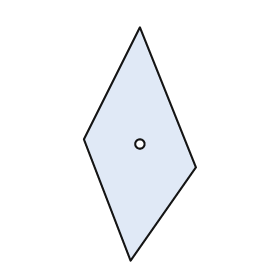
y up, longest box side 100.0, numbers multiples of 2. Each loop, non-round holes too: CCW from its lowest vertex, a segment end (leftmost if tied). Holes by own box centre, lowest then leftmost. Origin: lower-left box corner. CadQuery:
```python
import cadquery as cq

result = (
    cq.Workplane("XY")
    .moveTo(20.0, 0.0)
    .lineTo(48.0, 40.0)
    .lineTo(24.0, 100.0)
    .lineTo(0.0, 52.0)
    .close()
    .moveTo(24.0, 50.0)
    .circle(2.0)
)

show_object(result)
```